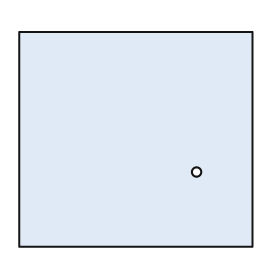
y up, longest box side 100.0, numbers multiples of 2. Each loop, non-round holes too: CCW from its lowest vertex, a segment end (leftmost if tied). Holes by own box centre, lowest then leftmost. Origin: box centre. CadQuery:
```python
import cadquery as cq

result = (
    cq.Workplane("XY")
    .moveTo(-50.0, -46.0)
    .lineTo(50.0, -46.0)
    .lineTo(50.0, 46.0)
    .lineTo(-50.0, 46.0)
    .close()
    .moveTo(26.0, -14.0)
    .circle(2.0)
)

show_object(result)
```